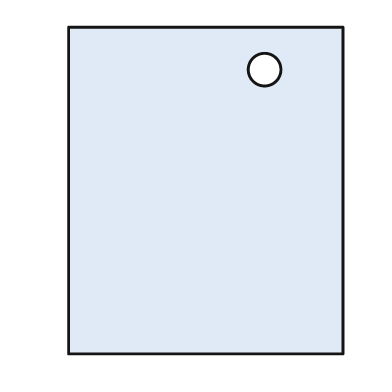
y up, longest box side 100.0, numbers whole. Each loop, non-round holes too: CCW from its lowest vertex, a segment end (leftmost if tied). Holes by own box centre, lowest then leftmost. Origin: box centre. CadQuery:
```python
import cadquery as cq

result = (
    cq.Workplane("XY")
    .moveTo(-42.0, -50.0)
    .lineTo(42.0, -50.0)
    .lineTo(42.0, 50.0)
    .lineTo(-42.0, 50.0)
    .close()
    .moveTo(18.0, 37.0)
    .circle(5.0)
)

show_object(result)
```